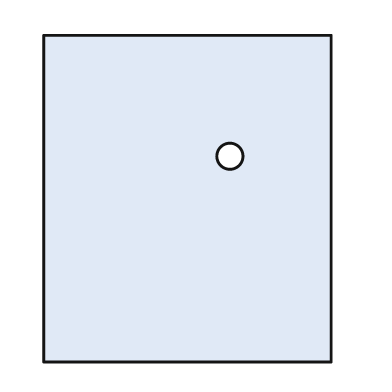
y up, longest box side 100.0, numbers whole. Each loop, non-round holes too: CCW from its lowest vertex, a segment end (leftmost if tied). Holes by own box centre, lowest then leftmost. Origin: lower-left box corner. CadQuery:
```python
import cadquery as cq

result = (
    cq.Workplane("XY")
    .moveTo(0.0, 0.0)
    .lineTo(88.0, 0.0)
    .lineTo(88.0, 100.0)
    .lineTo(0.0, 100.0)
    .close()
    .moveTo(57.0, 63.0)
    .circle(4.0)
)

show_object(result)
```